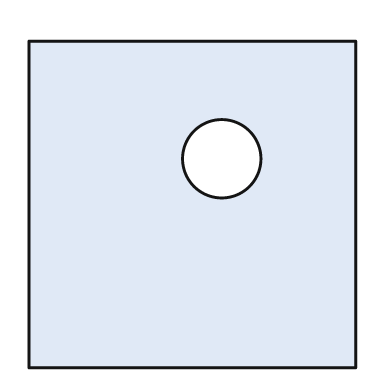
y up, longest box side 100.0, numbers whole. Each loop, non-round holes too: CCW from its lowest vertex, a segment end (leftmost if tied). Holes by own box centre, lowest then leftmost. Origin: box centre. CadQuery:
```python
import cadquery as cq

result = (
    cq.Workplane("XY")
    .moveTo(-50.0, -50.0)
    .lineTo(50.0, -50.0)
    .lineTo(50.0, 50.0)
    .lineTo(-50.0, 50.0)
    .close()
    .moveTo(9.0, 14.0)
    .circle(12.0)
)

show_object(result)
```